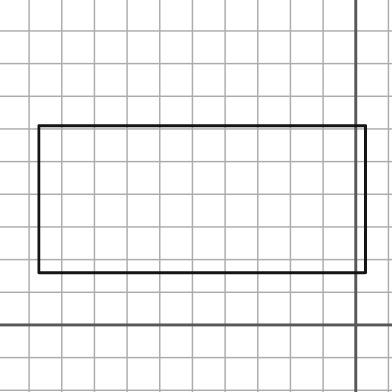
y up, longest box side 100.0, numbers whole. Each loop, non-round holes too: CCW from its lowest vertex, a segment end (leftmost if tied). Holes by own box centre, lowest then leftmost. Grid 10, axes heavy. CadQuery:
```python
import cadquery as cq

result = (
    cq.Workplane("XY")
    .moveTo(-97.0, 16.0)
    .lineTo(3.0, 16.0)
    .lineTo(3.0, 61.0)
    .lineTo(-97.0, 61.0)
    .close()
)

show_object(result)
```